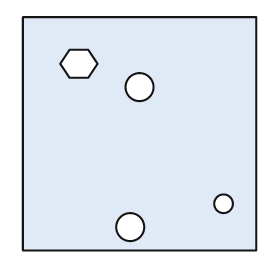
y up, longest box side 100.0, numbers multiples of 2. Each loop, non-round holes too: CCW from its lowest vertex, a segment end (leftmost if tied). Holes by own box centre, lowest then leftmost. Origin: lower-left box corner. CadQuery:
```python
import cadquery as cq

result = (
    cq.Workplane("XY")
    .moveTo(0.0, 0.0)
    .lineTo(100.0, 0.0)
    .lineTo(100.0, 100.0)
    .lineTo(0.0, 100.0)
    .close()
    .moveTo(46.0, 10.0)
    .circle(6.0)
    .moveTo(86.0, 20.0)
    .circle(4.0)
    .moveTo(50.0, 70.0)
    .circle(6.0)
    .moveTo(20.0, 74.0)
    .lineTo(28.0, 74.0)
    .lineTo(32.0, 80.0)
    .lineTo(28.0, 86.0)
    .lineTo(20.0, 86.0)
    .lineTo(16.0, 80.0)
    .close()
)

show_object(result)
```